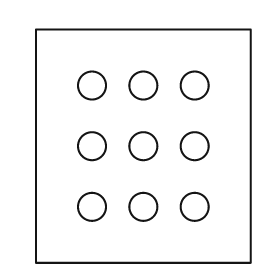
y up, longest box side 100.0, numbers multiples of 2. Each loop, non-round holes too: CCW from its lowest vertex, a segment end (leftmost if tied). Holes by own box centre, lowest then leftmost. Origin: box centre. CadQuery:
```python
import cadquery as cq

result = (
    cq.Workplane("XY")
    .moveTo(-46.0, -50.0)
    .lineTo(46.0, -50.0)
    .lineTo(46.0, 50.0)
    .lineTo(-46.0, 50.0)
    .close()
    .moveTo(-22.0, -26.0)
    .circle(6.0)
    .moveTo(0.0, -26.0)
    .circle(6.0)
    .moveTo(22.0, -26.0)
    .circle(6.0)
    .moveTo(-22.0, 0.0)
    .circle(6.0)
    .moveTo(0.0, 0.0)
    .circle(6.0)
    .moveTo(22.0, 0.0)
    .circle(6.0)
    .moveTo(-22.0, 26.0)
    .circle(6.0)
    .moveTo(0.0, 26.0)
    .circle(6.0)
    .moveTo(22.0, 26.0)
    .circle(6.0)
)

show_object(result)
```